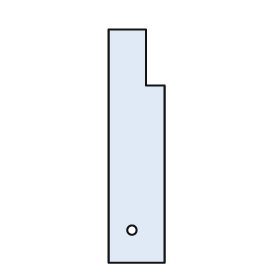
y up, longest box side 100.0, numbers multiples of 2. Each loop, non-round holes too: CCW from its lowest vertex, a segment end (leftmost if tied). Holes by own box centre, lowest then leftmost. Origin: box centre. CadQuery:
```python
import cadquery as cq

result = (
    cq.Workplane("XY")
    .moveTo(-12.0, -50.0)
    .lineTo(12.0, -50.0)
    .lineTo(12.0, 26.0)
    .lineTo(4.0, 26.0)
    .lineTo(4.0, 50.0)
    .lineTo(-12.0, 50.0)
    .close()
    .moveTo(-2.0, -36.0)
    .circle(2.0)
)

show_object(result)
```